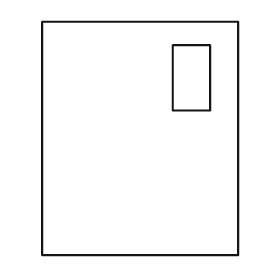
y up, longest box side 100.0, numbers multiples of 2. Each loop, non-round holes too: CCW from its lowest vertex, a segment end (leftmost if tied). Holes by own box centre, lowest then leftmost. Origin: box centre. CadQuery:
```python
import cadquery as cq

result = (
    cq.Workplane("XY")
    .moveTo(-42.0, -50.0)
    .lineTo(42.0, -50.0)
    .lineTo(42.0, 50.0)
    .lineTo(-42.0, 50.0)
    .close()
    .moveTo(14.0, 12.0)
    .lineTo(30.0, 12.0)
    .lineTo(30.0, 40.0)
    .lineTo(14.0, 40.0)
    .close()
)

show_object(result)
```